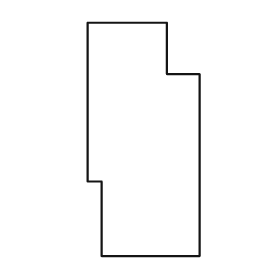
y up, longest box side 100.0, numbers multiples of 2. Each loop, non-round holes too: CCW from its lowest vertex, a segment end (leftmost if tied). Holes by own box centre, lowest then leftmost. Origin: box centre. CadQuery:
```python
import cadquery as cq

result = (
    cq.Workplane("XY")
    .moveTo(-18.0, -50.0)
    .lineTo(24.0, -50.0)
    .lineTo(24.0, 28.0)
    .lineTo(10.0, 28.0)
    .lineTo(10.0, 50.0)
    .lineTo(-24.0, 50.0)
    .lineTo(-24.0, -18.0)
    .lineTo(-18.0, -18.0)
    .close()
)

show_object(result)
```